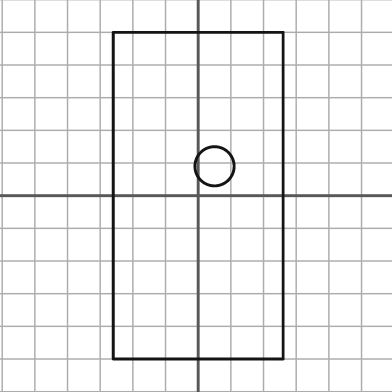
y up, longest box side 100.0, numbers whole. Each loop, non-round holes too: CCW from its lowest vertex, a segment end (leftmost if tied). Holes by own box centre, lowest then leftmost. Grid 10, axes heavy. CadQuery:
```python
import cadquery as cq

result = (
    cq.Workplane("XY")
    .moveTo(-26.0, -50.0)
    .lineTo(26.0, -50.0)
    .lineTo(26.0, 50.0)
    .lineTo(-26.0, 50.0)
    .close()
    .moveTo(5.0, 9.0)
    .circle(6.0)
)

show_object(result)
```